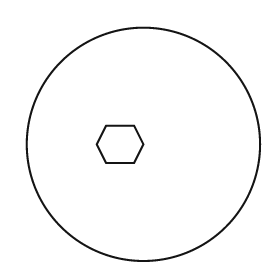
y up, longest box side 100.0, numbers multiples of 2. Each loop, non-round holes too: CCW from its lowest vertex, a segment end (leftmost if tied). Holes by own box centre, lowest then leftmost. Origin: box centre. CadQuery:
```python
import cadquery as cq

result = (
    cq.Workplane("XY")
    .moveTo(0.0, 0.0)
    .circle(50.0)
    .moveTo(-16.0, -8.0)
    .lineTo(-4.0, -8.0)
    .lineTo(0.0, 0.0)
    .lineTo(-4.0, 8.0)
    .lineTo(-16.0, 8.0)
    .lineTo(-20.0, 0.0)
    .close()
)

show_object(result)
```